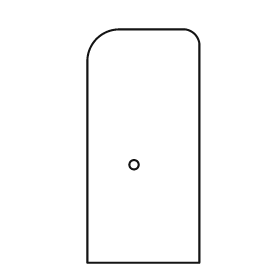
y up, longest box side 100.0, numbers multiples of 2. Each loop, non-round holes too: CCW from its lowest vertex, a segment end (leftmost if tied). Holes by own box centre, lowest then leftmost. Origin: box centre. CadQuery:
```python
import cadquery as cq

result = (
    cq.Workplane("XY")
    .moveTo(-24.0, -50.0)
    .lineTo(24.0, -50.0)
    .lineTo(24.0, 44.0)
    .threePointArc((22.0, 48.0), (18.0, 50.0))
    .lineTo(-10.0, 50.0)
    .threePointArc((-20.0, 46.0), (-24.0, 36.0))
    .close()
    .moveTo(-4.0, -8.0)
    .circle(2.0)
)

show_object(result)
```